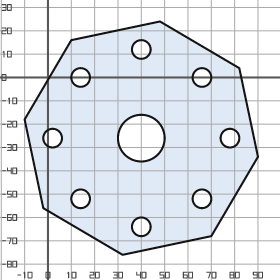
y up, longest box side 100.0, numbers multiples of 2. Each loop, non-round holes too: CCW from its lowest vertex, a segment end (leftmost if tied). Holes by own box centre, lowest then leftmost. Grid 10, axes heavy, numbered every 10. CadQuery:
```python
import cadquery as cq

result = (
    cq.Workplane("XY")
    .moveTo(32.0, -76.0)
    .lineTo(70.0, -68.0)
    .lineTo(90.0, -34.0)
    .lineTo(82.0, 4.0)
    .lineTo(48.0, 24.0)
    .lineTo(10.0, 16.0)
    .lineTo(-10.0, -18.0)
    .lineTo(-2.0, -56.0)
    .close()
    .moveTo(40.0, -64.0)
    .circle(4.0)
    .moveTo(14.0, -52.0)
    .circle(4.0)
    .moveTo(66.0, -52.0)
    .circle(4.0)
    .moveTo(2.0, -26.0)
    .circle(4.0)
    .moveTo(40.0, -26.0)
    .circle(10.0)
    .moveTo(78.0, -26.0)
    .circle(4.0)
    .moveTo(14.0, 0.0)
    .circle(4.0)
    .moveTo(66.0, 0.0)
    .circle(4.0)
    .moveTo(40.0, 12.0)
    .circle(4.0)
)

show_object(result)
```